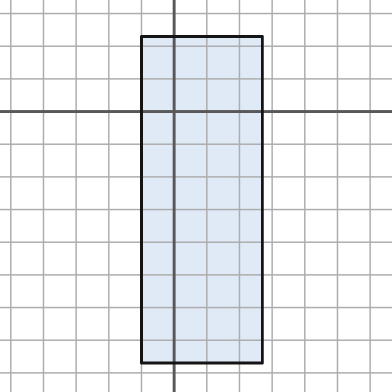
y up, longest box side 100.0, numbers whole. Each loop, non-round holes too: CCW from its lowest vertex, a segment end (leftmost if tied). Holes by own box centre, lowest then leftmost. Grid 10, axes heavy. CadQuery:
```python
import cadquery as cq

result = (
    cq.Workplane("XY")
    .moveTo(-10.0, -77.0)
    .lineTo(27.0, -77.0)
    .lineTo(27.0, 23.0)
    .lineTo(-10.0, 23.0)
    .close()
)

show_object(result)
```